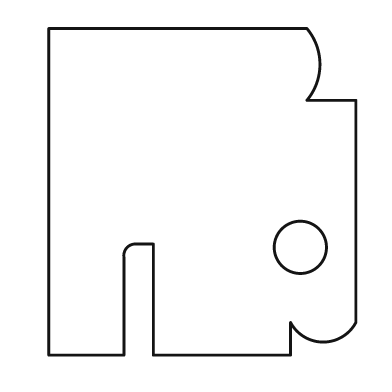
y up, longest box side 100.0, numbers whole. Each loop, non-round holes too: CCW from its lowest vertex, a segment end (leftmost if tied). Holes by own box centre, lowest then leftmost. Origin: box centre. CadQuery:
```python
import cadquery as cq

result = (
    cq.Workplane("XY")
    .moveTo(-47.0, -50.0)
    .lineTo(-24.0, -50.0)
    .lineTo(-24.0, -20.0)
    .threePointArc((-23.0, -17.0), (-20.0, -16.0))
    .lineTo(-15.0, -16.0)
    .lineTo(-15.0, -50.0)
    .lineTo(27.0, -50.0)
    .lineTo(27.0, -40.0)
    .threePointArc((37.0, -46.0), (47.0, -40.0))
    .lineTo(47.0, 28.0)
    .lineTo(32.0, 28.0)
    .threePointArc((36.0, 39.0), (32.0, 50.0))
    .lineTo(-47.0, 50.0)
    .close()
    .moveTo(30.0, -17.0)
    .circle(8.0)
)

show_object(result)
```